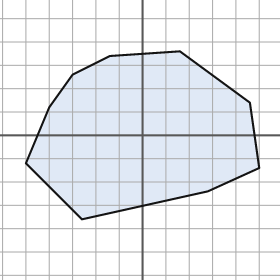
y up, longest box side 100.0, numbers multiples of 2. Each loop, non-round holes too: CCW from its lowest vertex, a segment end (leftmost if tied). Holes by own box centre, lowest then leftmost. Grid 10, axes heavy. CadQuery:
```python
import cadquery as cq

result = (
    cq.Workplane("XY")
    .moveTo(-26.0, -36.0)
    .lineTo(28.0, -24.0)
    .lineTo(50.0, -14.0)
    .lineTo(46.0, 14.0)
    .lineTo(16.0, 36.0)
    .lineTo(-14.0, 34.0)
    .lineTo(-30.0, 26.0)
    .lineTo(-40.0, 12.0)
    .lineTo(-50.0, -12.0)
    .close()
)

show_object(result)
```